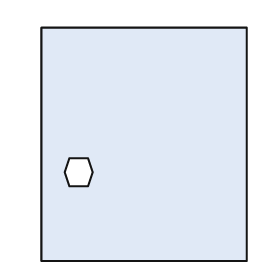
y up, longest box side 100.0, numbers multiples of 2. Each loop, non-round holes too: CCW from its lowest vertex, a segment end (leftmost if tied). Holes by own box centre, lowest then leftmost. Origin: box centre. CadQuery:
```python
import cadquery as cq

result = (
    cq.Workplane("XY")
    .moveTo(-44.0, -50.0)
    .lineTo(44.0, -50.0)
    .lineTo(44.0, 50.0)
    .lineTo(-44.0, 50.0)
    .close()
    .moveTo(-32.0, -18.0)
    .lineTo(-24.0, -18.0)
    .lineTo(-22.0, -12.0)
    .lineTo(-24.0, -6.0)
    .lineTo(-32.0, -6.0)
    .lineTo(-34.0, -12.0)
    .close()
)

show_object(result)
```